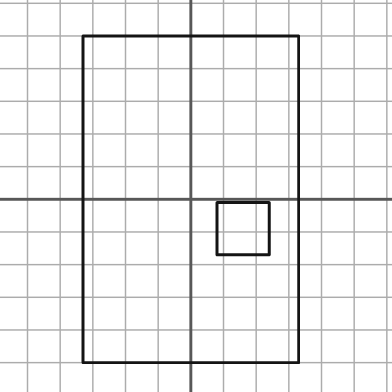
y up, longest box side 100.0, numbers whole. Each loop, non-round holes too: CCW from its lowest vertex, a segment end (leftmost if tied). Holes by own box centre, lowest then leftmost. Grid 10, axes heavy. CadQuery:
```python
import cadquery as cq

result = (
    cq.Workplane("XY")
    .moveTo(-33.0, -50.0)
    .lineTo(33.0, -50.0)
    .lineTo(33.0, 50.0)
    .lineTo(-33.0, 50.0)
    .close()
    .moveTo(8.0, -17.0)
    .lineTo(24.0, -17.0)
    .lineTo(24.0, -1.0)
    .lineTo(8.0, -1.0)
    .close()
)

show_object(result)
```